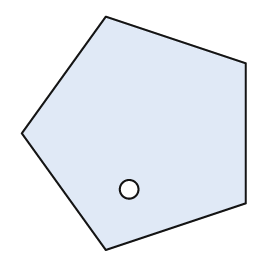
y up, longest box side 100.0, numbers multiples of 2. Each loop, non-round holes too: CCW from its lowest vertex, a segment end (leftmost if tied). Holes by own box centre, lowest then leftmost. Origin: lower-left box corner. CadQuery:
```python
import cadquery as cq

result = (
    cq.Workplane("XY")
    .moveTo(36.0, 0.0)
    .lineTo(96.0, 20.0)
    .lineTo(96.0, 80.0)
    .lineTo(36.0, 100.0)
    .lineTo(0.0, 50.0)
    .close()
    .moveTo(46.0, 26.0)
    .circle(4.0)
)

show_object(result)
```